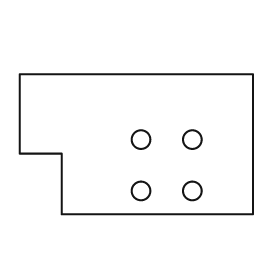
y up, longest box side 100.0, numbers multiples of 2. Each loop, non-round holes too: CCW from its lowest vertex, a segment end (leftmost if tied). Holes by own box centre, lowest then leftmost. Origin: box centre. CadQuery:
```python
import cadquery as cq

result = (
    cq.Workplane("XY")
    .moveTo(-32.0, -30.0)
    .lineTo(50.0, -30.0)
    .lineTo(50.0, 30.0)
    .lineTo(-50.0, 30.0)
    .lineTo(-50.0, -4.0)
    .lineTo(-32.0, -4.0)
    .close()
    .moveTo(2.0, -20.0)
    .circle(4.0)
    .moveTo(24.0, -20.0)
    .circle(4.0)
    .moveTo(2.0, 2.0)
    .circle(4.0)
    .moveTo(24.0, 2.0)
    .circle(4.0)
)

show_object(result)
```